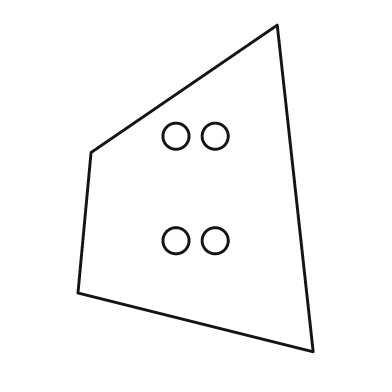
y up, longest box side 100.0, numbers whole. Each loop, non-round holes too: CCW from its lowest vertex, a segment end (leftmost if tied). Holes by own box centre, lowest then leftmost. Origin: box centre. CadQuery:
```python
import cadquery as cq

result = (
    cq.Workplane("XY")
    .moveTo(36.0, -50.0)
    .lineTo(25.0, 50.0)
    .lineTo(-32.0, 11.0)
    .lineTo(-36.0, -32.0)
    .close()
    .moveTo(-6.0, -16.0)
    .circle(4.0)
    .moveTo(6.0, -16.0)
    .circle(4.0)
    .moveTo(-6.0, 16.0)
    .circle(4.0)
    .moveTo(6.0, 16.0)
    .circle(4.0)
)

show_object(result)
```